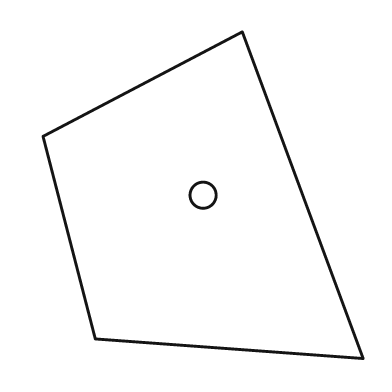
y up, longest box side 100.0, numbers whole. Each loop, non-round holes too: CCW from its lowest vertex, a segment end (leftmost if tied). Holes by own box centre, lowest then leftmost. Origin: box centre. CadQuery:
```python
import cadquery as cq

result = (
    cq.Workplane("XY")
    .moveTo(49.0, -50.0)
    .lineTo(12.0, 50.0)
    .lineTo(-49.0, 18.0)
    .lineTo(-33.0, -44.0)
    .close()
    .moveTo(0.0, 0.0)
    .circle(4.0)
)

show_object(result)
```